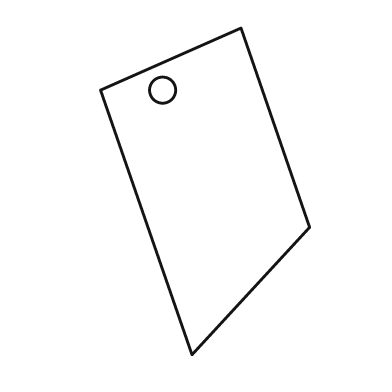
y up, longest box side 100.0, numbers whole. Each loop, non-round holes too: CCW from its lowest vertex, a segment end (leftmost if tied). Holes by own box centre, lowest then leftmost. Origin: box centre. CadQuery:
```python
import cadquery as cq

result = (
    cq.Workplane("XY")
    .moveTo(-4.0, -50.0)
    .lineTo(32.0, -11.0)
    .lineTo(11.0, 50.0)
    .lineTo(-32.0, 31.0)
    .close()
    .moveTo(-13.0, 31.0)
    .circle(4.0)
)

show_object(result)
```